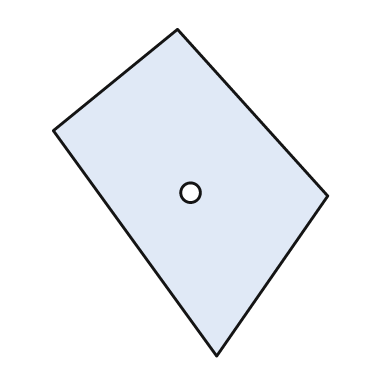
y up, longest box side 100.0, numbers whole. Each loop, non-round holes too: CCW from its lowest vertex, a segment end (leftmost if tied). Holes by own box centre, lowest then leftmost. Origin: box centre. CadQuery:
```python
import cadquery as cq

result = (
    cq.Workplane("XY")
    .moveTo(8.0, -50.0)
    .lineTo(42.0, -1.0)
    .lineTo(-4.0, 50.0)
    .lineTo(-42.0, 19.0)
    .close()
    .moveTo(0.0, 0.0)
    .circle(3.0)
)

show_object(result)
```